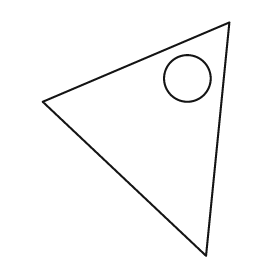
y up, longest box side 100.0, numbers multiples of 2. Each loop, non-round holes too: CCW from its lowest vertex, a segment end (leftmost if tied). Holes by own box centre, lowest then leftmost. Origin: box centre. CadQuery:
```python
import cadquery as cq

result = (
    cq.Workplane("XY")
    .moveTo(30.0, -50.0)
    .lineTo(40.0, 50.0)
    .lineTo(-40.0, 16.0)
    .close()
    .moveTo(22.0, 26.0)
    .circle(10.0)
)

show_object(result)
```